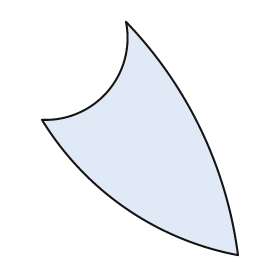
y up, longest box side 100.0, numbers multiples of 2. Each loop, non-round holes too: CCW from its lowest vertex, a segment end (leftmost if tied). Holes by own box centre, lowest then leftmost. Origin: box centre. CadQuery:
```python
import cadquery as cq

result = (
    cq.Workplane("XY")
    .moveTo(42.0, -50.0)
    .threePointArc((26.0, 4.0), (-6.0, 50.0))
    .threePointArc((-14.0, 20.0), (-42.0, 8.0))
    .threePointArc((-6.0, -30.0), (42.0, -50.0))
    .close()
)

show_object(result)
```